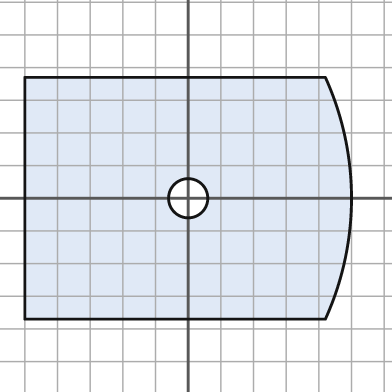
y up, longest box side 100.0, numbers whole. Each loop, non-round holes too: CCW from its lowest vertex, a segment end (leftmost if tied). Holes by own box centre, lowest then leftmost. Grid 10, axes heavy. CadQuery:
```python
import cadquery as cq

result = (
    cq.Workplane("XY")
    .moveTo(-50.0, -37.0)
    .lineTo(42.0, -37.0)
    .threePointArc((50.0, 0.0), (42.0, 37.0))
    .lineTo(-50.0, 37.0)
    .close()
    .moveTo(0.0, 0.0)
    .circle(6.0)
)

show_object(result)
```